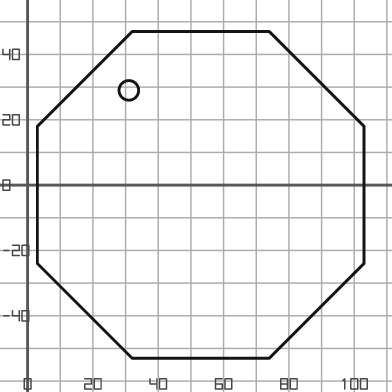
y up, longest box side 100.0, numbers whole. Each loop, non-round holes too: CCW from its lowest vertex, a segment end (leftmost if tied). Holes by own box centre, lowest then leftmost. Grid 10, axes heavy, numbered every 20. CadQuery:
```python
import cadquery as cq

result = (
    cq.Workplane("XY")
    .moveTo(32.0, -53.0)
    .lineTo(74.0, -53.0)
    .lineTo(103.0, -24.0)
    .lineTo(103.0, 18.0)
    .lineTo(74.0, 47.0)
    .lineTo(32.0, 47.0)
    .lineTo(3.0, 18.0)
    .lineTo(3.0, -24.0)
    .close()
    .moveTo(31.0, 29.0)
    .circle(3.0)
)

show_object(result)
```